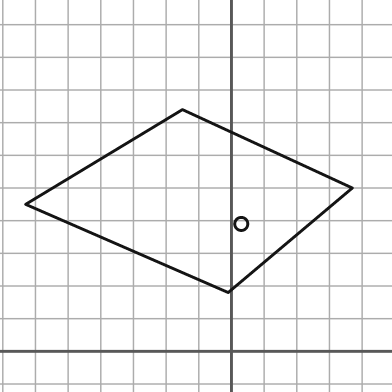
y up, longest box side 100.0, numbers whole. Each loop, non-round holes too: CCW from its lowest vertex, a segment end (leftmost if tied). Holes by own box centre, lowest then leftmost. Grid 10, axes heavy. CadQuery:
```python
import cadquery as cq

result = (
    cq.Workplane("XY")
    .moveTo(-1.0, 18.0)
    .lineTo(37.0, 50.0)
    .lineTo(-15.0, 74.0)
    .lineTo(-63.0, 45.0)
    .close()
    .moveTo(3.0, 39.0)
    .circle(2.0)
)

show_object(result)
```